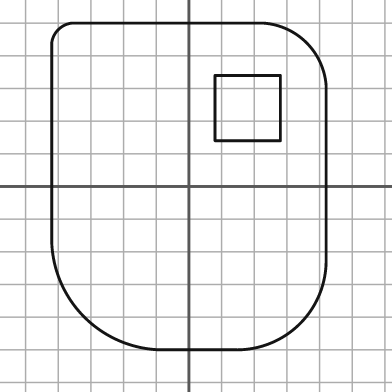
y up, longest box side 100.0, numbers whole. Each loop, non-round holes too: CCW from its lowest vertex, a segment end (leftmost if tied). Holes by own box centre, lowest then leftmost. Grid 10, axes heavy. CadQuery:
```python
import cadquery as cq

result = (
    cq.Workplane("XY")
    .moveTo(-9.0, -50.0)
    .lineTo(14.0, -50.0)
    .threePointArc((34.0, -42.0), (42.0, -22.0))
    .lineTo(42.0, 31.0)
    .threePointArc((36.0, 44.0), (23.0, 50.0))
    .lineTo(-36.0, 50.0)
    .threePointArc((-40.0, 48.0), (-42.0, 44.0))
    .lineTo(-42.0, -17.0)
    .threePointArc((-32.0, -40.0), (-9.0, -50.0))
    .close()
    .moveTo(8.0, 14.0)
    .lineTo(28.0, 14.0)
    .lineTo(28.0, 34.0)
    .lineTo(8.0, 34.0)
    .close()
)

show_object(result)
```